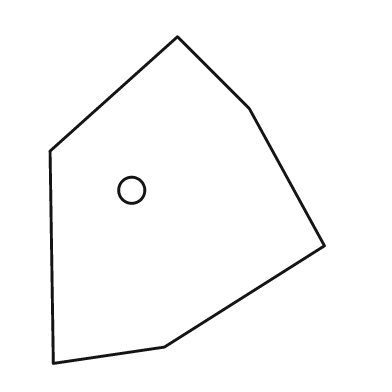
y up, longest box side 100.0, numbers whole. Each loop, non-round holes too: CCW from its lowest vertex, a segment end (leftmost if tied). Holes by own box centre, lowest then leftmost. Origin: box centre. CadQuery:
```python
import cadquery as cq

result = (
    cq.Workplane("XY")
    .moveTo(-41.0, -50.0)
    .lineTo(-7.0, -45.0)
    .lineTo(42.0, -14.0)
    .lineTo(19.0, 28.0)
    .lineTo(-3.0, 50.0)
    .lineTo(-42.0, 15.0)
    .close()
    .moveTo(-17.0, 3.0)
    .circle(4.0)
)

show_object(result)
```